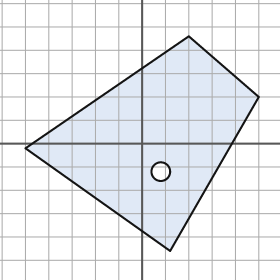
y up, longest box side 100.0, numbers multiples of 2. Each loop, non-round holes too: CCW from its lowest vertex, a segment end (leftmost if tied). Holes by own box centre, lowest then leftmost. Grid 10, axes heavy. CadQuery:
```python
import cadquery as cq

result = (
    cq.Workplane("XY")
    .moveTo(12.0, -46.0)
    .lineTo(50.0, 20.0)
    .lineTo(20.0, 46.0)
    .lineTo(-50.0, -2.0)
    .close()
    .moveTo(8.0, -12.0)
    .circle(4.0)
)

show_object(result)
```